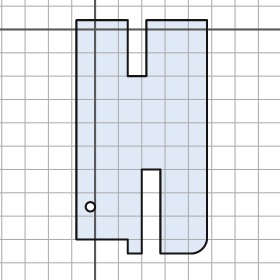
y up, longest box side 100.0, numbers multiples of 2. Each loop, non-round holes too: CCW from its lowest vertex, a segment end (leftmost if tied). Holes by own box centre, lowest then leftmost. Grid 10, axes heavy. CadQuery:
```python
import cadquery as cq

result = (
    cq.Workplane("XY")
    .moveTo(14.0, -96.0)
    .lineTo(20.0, -96.0)
    .lineTo(20.0, -60.0)
    .lineTo(28.0, -60.0)
    .lineTo(28.0, -96.0)
    .lineTo(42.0, -96.0)
    .threePointArc((46.0, -94.0), (48.0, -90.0))
    .lineTo(48.0, 4.0)
    .lineTo(22.0, 4.0)
    .lineTo(22.0, -20.0)
    .lineTo(14.0, -20.0)
    .lineTo(14.0, 4.0)
    .lineTo(-8.0, 4.0)
    .lineTo(-8.0, -90.0)
    .lineTo(14.0, -90.0)
    .close()
    .moveTo(-2.0, -76.0)
    .circle(2.0)
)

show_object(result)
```